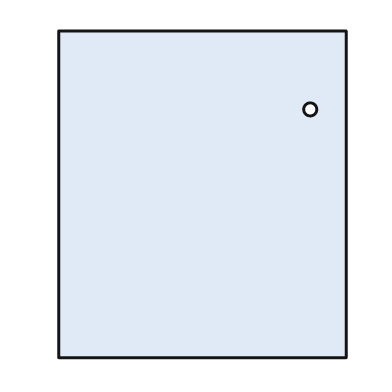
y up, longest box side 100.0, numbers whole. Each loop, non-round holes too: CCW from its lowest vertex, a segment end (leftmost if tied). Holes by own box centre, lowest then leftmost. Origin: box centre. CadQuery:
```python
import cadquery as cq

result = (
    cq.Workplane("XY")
    .moveTo(-44.0, -50.0)
    .lineTo(44.0, -50.0)
    .lineTo(44.0, 50.0)
    .lineTo(-44.0, 50.0)
    .close()
    .moveTo(33.0, 26.0)
    .circle(2.0)
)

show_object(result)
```